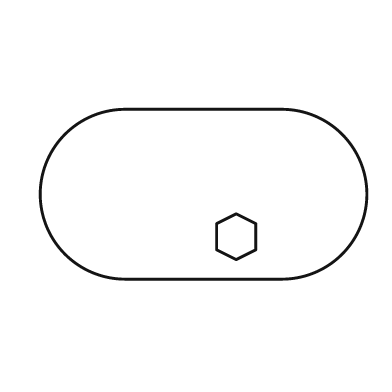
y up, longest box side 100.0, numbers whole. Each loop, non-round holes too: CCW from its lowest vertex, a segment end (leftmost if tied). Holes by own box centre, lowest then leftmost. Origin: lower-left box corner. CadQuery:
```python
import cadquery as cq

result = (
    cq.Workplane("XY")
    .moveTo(26.0, 0.0)
    .lineTo(74.0, 0.0)
    .threePointArc((100.0, 26.0), (74.0, 52.0))
    .lineTo(26.0, 52.0)
    .threePointArc((0.0, 26.0), (26.0, 0.0))
    .close()
    .moveTo(60.0, 6.0)
    .lineTo(66.0, 9.0)
    .lineTo(66.0, 17.0)
    .lineTo(60.0, 20.0)
    .lineTo(54.0, 17.0)
    .lineTo(54.0, 9.0)
    .close()
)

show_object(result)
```